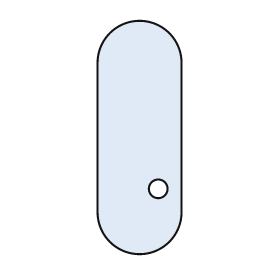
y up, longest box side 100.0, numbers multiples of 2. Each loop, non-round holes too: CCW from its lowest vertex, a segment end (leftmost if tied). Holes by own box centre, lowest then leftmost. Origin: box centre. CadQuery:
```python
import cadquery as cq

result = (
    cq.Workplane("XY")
    .moveTo(-18.0, -32.0)
    .threePointArc((0.0, -50.0), (18.0, -32.0))
    .lineTo(18.0, 32.0)
    .threePointArc((0.0, 50.0), (-18.0, 32.0))
    .close()
    .moveTo(8.0, -22.0)
    .circle(4.0)
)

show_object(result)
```